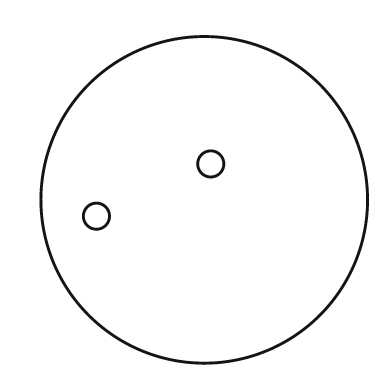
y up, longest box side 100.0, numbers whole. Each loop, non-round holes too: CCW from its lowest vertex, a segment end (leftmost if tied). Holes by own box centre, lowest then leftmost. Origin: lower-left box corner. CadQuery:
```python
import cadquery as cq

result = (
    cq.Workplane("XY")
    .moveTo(50.0, 50.0)
    .circle(50.0)
    .moveTo(17.0, 45.0)
    .circle(4.0)
    .moveTo(52.0, 61.0)
    .circle(4.0)
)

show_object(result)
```